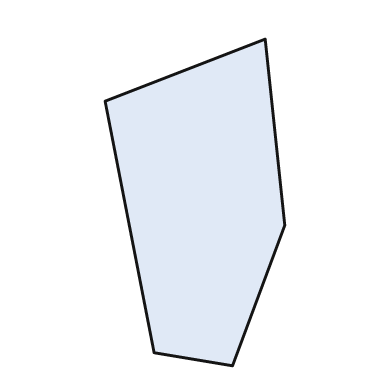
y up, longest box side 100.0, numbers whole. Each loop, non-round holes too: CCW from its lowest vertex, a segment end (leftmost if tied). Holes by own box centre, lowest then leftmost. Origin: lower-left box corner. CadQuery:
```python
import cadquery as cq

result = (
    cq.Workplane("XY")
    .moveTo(39.0, 0.0)
    .lineTo(55.0, 43.0)
    .lineTo(49.0, 100.0)
    .lineTo(0.0, 81.0)
    .lineTo(15.0, 4.0)
    .close()
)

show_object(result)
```